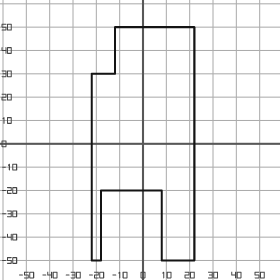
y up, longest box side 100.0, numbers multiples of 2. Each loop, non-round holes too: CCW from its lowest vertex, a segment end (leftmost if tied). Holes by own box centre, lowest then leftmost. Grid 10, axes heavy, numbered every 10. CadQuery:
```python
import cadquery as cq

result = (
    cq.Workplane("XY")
    .moveTo(-22.0, -50.0)
    .lineTo(-18.0, -50.0)
    .lineTo(-18.0, -20.0)
    .lineTo(8.0, -20.0)
    .lineTo(8.0, -50.0)
    .lineTo(22.0, -50.0)
    .lineTo(22.0, 50.0)
    .lineTo(-12.0, 50.0)
    .lineTo(-12.0, 30.0)
    .lineTo(-22.0, 30.0)
    .close()
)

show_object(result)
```